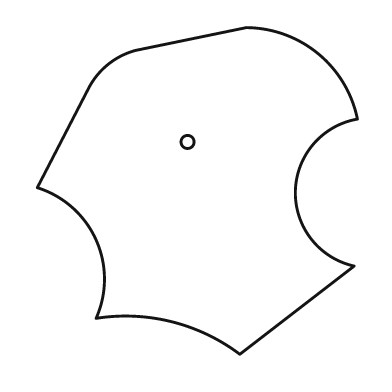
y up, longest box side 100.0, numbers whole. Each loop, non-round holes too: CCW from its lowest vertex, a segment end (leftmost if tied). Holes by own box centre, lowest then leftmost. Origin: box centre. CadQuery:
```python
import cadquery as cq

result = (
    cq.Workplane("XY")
    .moveTo(13.0, -50.0)
    .lineTo(48.0, -23.0)
    .threePointArc((30.0, 0.0), (49.0, 22.0))
    .threePointArc((37.0, 42.0), (15.0, 50.0))
    .lineTo(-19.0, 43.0)
    .threePointArc((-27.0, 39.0), (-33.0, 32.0))
    .lineTo(-49.0, 1.0)
    .threePointArc((-31.0, -15.0), (-31.0, -39.0))
    .threePointArc((-8.0, -40.0), (13.0, -50.0))
    .close()
    .moveTo(-3.0, 15.0)
    .circle(2.0)
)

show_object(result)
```